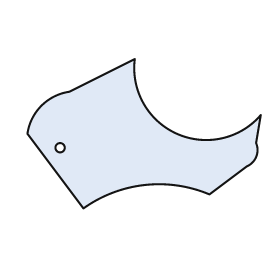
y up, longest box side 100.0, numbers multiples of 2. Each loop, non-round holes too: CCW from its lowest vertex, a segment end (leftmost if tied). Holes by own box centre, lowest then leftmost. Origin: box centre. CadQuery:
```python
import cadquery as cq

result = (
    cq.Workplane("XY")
    .moveTo(-26.0, -32.0)
    .threePointArc((0.0, -22.0), (28.0, -26.0))
    .lineTo(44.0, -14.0)
    .threePointArc((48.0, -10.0), (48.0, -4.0))
    .lineTo(50.0, 8.0)
    .threePointArc((14.0, 0.0), (-4.0, 32.0))
    .lineTo(-32.0, 18.0)
    .threePointArc((-44.0, 12.0), (-50.0, 0.0))
    .close()
    .moveTo(-36.0, -6.0)
    .circle(2.0)
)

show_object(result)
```